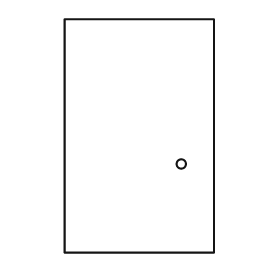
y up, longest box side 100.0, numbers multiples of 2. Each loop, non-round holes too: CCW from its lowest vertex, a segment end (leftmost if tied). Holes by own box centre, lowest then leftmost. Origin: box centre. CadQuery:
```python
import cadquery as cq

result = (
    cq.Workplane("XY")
    .moveTo(-32.0, -50.0)
    .lineTo(32.0, -50.0)
    .lineTo(32.0, 50.0)
    .lineTo(-32.0, 50.0)
    .close()
    .moveTo(18.0, -12.0)
    .circle(2.0)
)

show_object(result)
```